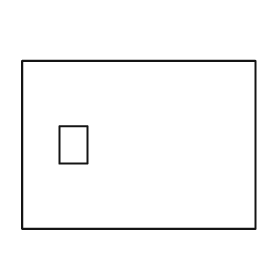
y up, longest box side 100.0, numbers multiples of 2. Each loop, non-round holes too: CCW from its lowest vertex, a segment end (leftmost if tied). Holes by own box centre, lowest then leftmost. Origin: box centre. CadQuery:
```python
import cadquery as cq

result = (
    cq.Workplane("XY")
    .moveTo(-50.0, -36.0)
    .lineTo(50.0, -36.0)
    .lineTo(50.0, 36.0)
    .lineTo(-50.0, 36.0)
    .close()
    .moveTo(-34.0, -8.0)
    .lineTo(-22.0, -8.0)
    .lineTo(-22.0, 8.0)
    .lineTo(-34.0, 8.0)
    .close()
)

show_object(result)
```